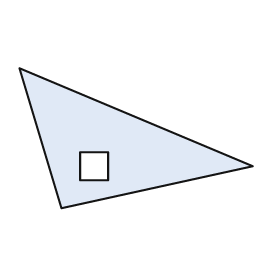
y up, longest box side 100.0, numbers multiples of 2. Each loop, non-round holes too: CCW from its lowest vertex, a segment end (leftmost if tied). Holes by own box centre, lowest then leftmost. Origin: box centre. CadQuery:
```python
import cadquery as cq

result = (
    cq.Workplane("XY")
    .moveTo(-32.0, -30.0)
    .lineTo(50.0, -12.0)
    .lineTo(-50.0, 30.0)
    .close()
    .moveTo(-24.0, -18.0)
    .lineTo(-12.0, -18.0)
    .lineTo(-12.0, -6.0)
    .lineTo(-24.0, -6.0)
    .close()
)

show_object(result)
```